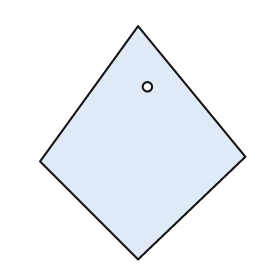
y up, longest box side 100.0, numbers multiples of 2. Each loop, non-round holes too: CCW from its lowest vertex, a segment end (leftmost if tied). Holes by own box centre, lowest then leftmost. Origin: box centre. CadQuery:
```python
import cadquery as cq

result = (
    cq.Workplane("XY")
    .moveTo(-2.0, -50.0)
    .lineTo(44.0, -6.0)
    .lineTo(-2.0, 50.0)
    .lineTo(-44.0, -8.0)
    .close()
    .moveTo(2.0, 24.0)
    .circle(2.0)
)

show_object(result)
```